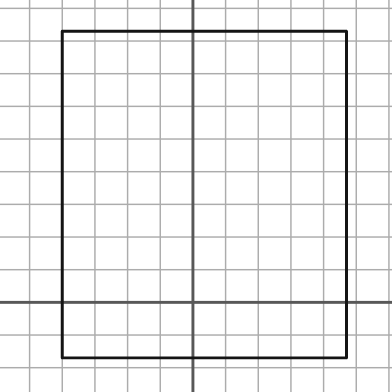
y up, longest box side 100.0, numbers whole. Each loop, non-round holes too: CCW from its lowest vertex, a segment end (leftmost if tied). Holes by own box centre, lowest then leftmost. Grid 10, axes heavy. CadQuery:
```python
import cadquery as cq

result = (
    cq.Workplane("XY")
    .moveTo(-40.0, -17.0)
    .lineTo(47.0, -17.0)
    .lineTo(47.0, 83.0)
    .lineTo(-40.0, 83.0)
    .close()
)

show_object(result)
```